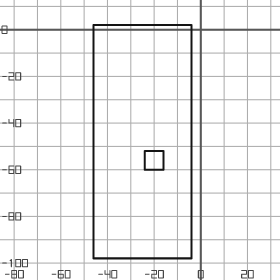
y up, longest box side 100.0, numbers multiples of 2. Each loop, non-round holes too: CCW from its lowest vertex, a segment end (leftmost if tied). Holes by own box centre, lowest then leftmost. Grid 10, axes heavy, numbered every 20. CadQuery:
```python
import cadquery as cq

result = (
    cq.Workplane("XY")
    .moveTo(-46.0, -98.0)
    .lineTo(-4.0, -98.0)
    .lineTo(-4.0, 2.0)
    .lineTo(-46.0, 2.0)
    .close()
    .moveTo(-24.0, -60.0)
    .lineTo(-16.0, -60.0)
    .lineTo(-16.0, -52.0)
    .lineTo(-24.0, -52.0)
    .close()
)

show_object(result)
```